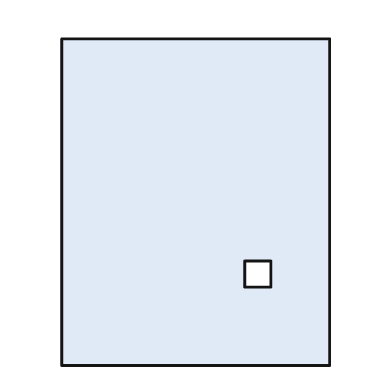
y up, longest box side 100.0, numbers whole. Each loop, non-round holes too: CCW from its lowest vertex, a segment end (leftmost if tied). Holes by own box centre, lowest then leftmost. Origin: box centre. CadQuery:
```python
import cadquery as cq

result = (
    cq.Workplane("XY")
    .moveTo(-41.0, -50.0)
    .lineTo(41.0, -50.0)
    .lineTo(41.0, 50.0)
    .lineTo(-41.0, 50.0)
    .close()
    .moveTo(15.0, -26.0)
    .lineTo(23.0, -26.0)
    .lineTo(23.0, -18.0)
    .lineTo(15.0, -18.0)
    .close()
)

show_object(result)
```